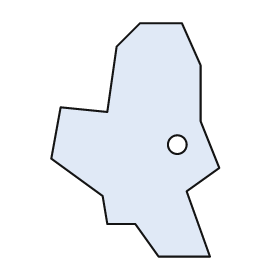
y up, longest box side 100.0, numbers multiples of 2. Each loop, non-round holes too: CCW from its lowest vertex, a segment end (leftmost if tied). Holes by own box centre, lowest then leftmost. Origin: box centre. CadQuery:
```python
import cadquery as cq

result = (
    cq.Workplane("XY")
    .moveTo(10.0, -50.0)
    .lineTo(32.0, -50.0)
    .lineTo(22.0, -22.0)
    .lineTo(36.0, -12.0)
    .lineTo(28.0, 8.0)
    .lineTo(28.0, 32.0)
    .lineTo(20.0, 50.0)
    .lineTo(2.0, 50.0)
    .lineTo(-8.0, 40.0)
    .lineTo(-12.0, 12.0)
    .lineTo(-32.0, 14.0)
    .lineTo(-36.0, -8.0)
    .lineTo(-14.0, -24.0)
    .lineTo(-12.0, -36.0)
    .lineTo(0.0, -36.0)
    .close()
    .moveTo(18.0, -2.0)
    .circle(4.0)
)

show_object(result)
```